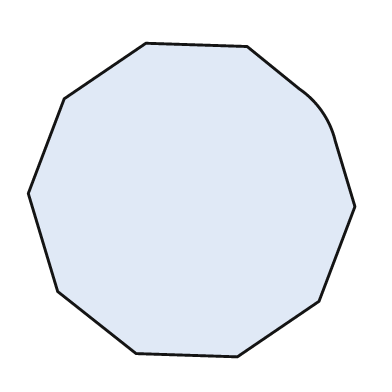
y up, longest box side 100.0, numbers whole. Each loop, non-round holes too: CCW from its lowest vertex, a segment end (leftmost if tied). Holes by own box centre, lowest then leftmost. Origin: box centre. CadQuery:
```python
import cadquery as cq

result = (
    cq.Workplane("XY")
    .moveTo(14.0, -48.0)
    .lineTo(39.0, -31.0)
    .lineTo(50.0, -2.0)
    .lineTo(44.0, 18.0)
    .threePointArc((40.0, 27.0), (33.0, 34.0))
    .lineTo(17.0, 47.0)
    .lineTo(-14.0, 48.0)
    .lineTo(-39.0, 31.0)
    .lineTo(-50.0, 2.0)
    .lineTo(-41.0, -28.0)
    .lineTo(-17.0, -47.0)
    .close()
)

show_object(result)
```